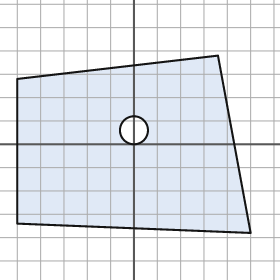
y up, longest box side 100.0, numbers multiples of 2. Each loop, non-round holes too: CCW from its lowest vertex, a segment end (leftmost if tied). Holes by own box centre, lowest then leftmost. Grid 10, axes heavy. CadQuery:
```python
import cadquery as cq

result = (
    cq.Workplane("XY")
    .moveTo(50.0, -38.0)
    .lineTo(36.0, 38.0)
    .lineTo(-50.0, 28.0)
    .lineTo(-50.0, -34.0)
    .close()
    .moveTo(0.0, 6.0)
    .circle(6.0)
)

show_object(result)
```